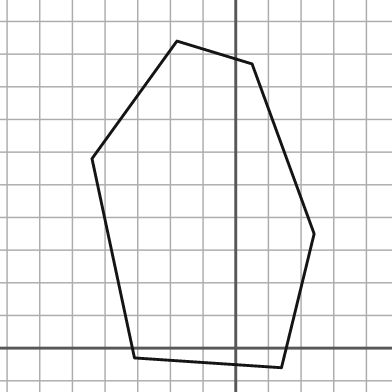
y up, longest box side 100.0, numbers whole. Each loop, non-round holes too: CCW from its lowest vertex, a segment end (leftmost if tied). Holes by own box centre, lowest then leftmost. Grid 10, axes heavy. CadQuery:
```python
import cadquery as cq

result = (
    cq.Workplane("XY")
    .moveTo(14.0, -6.0)
    .lineTo(24.0, 35.0)
    .lineTo(5.0, 87.0)
    .lineTo(-18.0, 94.0)
    .lineTo(-44.0, 58.0)
    .lineTo(-31.0, -3.0)
    .close()
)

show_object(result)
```